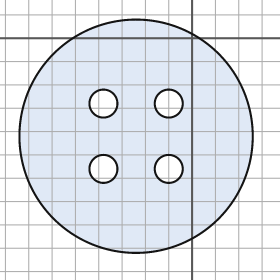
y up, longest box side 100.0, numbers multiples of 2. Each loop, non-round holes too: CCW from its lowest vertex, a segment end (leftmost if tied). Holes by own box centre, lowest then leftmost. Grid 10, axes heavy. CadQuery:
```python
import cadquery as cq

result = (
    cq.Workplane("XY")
    .moveTo(-24.0, -42.0)
    .circle(50.0)
    .moveTo(-38.0, -56.0)
    .circle(6.0)
    .moveTo(-10.0, -56.0)
    .circle(6.0)
    .moveTo(-38.0, -28.0)
    .circle(6.0)
    .moveTo(-10.0, -28.0)
    .circle(6.0)
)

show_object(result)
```